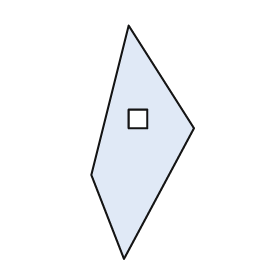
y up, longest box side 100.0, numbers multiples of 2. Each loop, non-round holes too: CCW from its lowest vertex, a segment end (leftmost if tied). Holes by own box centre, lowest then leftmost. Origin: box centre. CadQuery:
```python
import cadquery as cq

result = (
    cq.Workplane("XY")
    .moveTo(-8.0, -50.0)
    .lineTo(22.0, 6.0)
    .lineTo(-6.0, 50.0)
    .lineTo(-22.0, -14.0)
    .close()
    .moveTo(-6.0, 6.0)
    .lineTo(2.0, 6.0)
    .lineTo(2.0, 14.0)
    .lineTo(-6.0, 14.0)
    .close()
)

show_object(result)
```